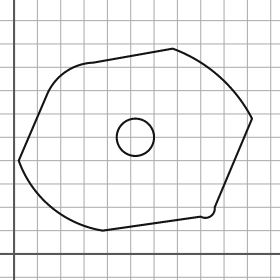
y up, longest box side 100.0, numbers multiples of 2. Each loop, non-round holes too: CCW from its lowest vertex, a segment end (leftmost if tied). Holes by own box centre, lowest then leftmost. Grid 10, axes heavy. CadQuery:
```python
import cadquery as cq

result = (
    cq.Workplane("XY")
    .moveTo(38.0, 10.0)
    .lineTo(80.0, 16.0)
    .threePointArc((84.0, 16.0), (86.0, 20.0))
    .lineTo(102.0, 58.0)
    .threePointArc((88.0, 76.0), (68.0, 88.0))
    .lineTo(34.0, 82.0)
    .threePointArc((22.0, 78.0), (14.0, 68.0))
    .lineTo(2.0, 40.0)
    .threePointArc((16.0, 20.0), (38.0, 10.0))
    .close()
    .moveTo(52.0, 50.0)
    .circle(8.0)
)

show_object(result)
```